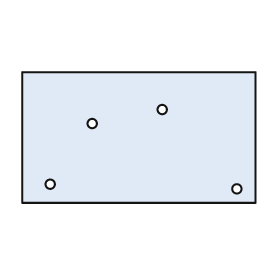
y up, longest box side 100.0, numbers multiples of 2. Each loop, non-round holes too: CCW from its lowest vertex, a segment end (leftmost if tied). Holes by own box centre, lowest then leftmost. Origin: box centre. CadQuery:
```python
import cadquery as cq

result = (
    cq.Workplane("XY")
    .moveTo(-50.0, -28.0)
    .lineTo(50.0, -28.0)
    .lineTo(50.0, 28.0)
    .lineTo(-50.0, 28.0)
    .close()
    .moveTo(42.0, -22.0)
    .circle(2.0)
    .moveTo(-38.0, -20.0)
    .circle(2.0)
    .moveTo(-20.0, 6.0)
    .circle(2.0)
    .moveTo(10.0, 12.0)
    .circle(2.0)
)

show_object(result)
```